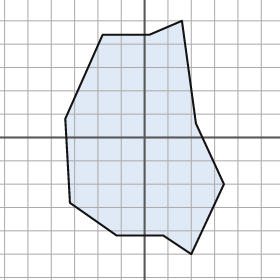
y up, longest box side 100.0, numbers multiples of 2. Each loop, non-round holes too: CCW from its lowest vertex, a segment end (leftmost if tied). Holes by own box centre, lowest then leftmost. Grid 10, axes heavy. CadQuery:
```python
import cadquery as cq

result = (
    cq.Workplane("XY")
    .moveTo(20.0, -50.0)
    .lineTo(34.0, -20.0)
    .lineTo(22.0, 6.0)
    .lineTo(16.0, 50.0)
    .lineTo(2.0, 44.0)
    .lineTo(-18.0, 44.0)
    .lineTo(-34.0, 8.0)
    .lineTo(-32.0, -28.0)
    .lineTo(-12.0, -42.0)
    .lineTo(8.0, -42.0)
    .close()
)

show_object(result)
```